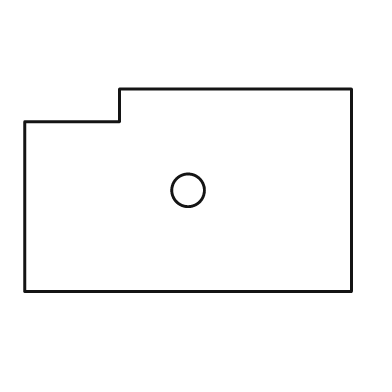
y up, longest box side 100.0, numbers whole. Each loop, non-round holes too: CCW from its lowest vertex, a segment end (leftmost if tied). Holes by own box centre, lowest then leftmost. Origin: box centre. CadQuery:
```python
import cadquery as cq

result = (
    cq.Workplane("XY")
    .moveTo(-50.0, -31.0)
    .lineTo(50.0, -31.0)
    .lineTo(50.0, 31.0)
    .lineTo(-21.0, 31.0)
    .lineTo(-21.0, 21.0)
    .lineTo(-50.0, 21.0)
    .close()
    .moveTo(0.0, 0.0)
    .circle(5.0)
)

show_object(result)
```